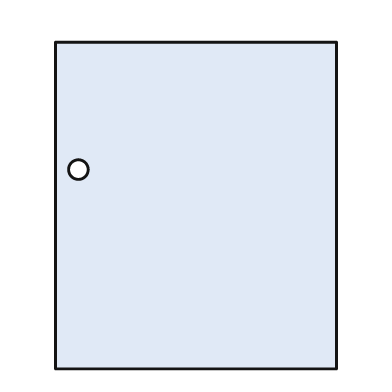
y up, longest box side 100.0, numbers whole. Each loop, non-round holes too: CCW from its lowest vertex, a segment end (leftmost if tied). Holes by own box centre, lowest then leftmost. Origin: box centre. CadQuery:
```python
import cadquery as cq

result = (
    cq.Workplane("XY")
    .moveTo(-43.0, -50.0)
    .lineTo(43.0, -50.0)
    .lineTo(43.0, 50.0)
    .lineTo(-43.0, 50.0)
    .close()
    .moveTo(-36.0, 11.0)
    .circle(3.0)
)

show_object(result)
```